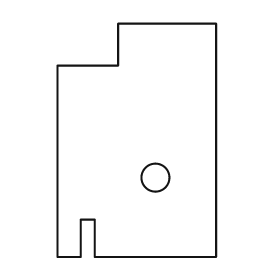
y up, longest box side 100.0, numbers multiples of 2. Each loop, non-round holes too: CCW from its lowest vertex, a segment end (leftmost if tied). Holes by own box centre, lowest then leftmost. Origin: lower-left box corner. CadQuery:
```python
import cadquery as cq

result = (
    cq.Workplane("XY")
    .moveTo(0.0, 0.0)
    .lineTo(10.0, 0.0)
    .lineTo(10.0, 16.0)
    .lineTo(16.0, 16.0)
    .lineTo(16.0, 0.0)
    .lineTo(68.0, 0.0)
    .lineTo(68.0, 100.0)
    .lineTo(26.0, 100.0)
    .lineTo(26.0, 82.0)
    .lineTo(0.0, 82.0)
    .close()
    .moveTo(42.0, 34.0)
    .circle(6.0)
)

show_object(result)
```